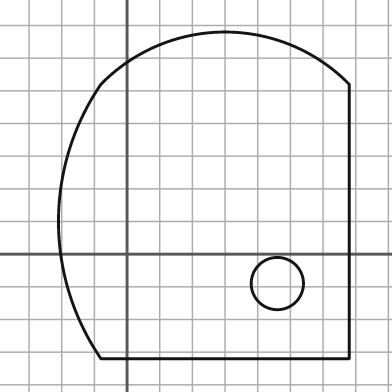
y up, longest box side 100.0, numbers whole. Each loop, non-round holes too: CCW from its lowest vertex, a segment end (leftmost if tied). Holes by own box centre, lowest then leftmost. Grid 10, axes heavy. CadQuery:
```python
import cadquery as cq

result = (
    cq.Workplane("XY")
    .moveTo(-8.0, -32.0)
    .lineTo(68.0, -32.0)
    .lineTo(68.0, 52.0)
    .threePointArc((30.0, 68.0), (-8.0, 52.0))
    .threePointArc((-21.0, 10.0), (-8.0, -32.0))
    .close()
    .moveTo(46.0, -9.0)
    .circle(8.0)
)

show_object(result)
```